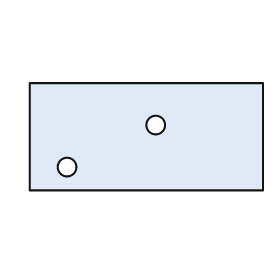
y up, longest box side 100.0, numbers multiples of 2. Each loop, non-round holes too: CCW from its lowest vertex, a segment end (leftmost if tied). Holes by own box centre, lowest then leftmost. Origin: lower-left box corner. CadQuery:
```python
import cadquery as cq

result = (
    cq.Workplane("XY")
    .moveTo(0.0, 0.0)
    .lineTo(100.0, 0.0)
    .lineTo(100.0, 46.0)
    .lineTo(0.0, 46.0)
    .close()
    .moveTo(16.0, 10.0)
    .circle(4.0)
    .moveTo(54.0, 28.0)
    .circle(4.0)
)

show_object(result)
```